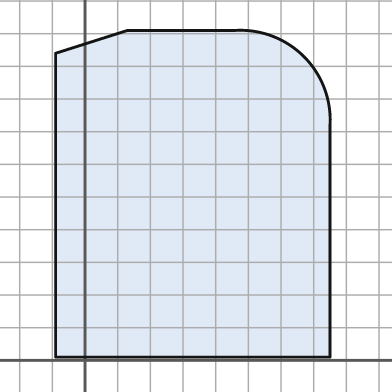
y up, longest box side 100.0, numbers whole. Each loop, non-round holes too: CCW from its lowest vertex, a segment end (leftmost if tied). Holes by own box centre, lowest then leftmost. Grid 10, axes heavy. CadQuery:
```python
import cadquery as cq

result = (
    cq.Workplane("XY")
    .moveTo(-9.0, 1.0)
    .lineTo(75.0, 1.0)
    .lineTo(75.0, 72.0)
    .threePointArc((67.0, 93.0), (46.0, 101.0))
    .lineTo(13.0, 101.0)
    .lineTo(-9.0, 94.0)
    .close()
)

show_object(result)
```